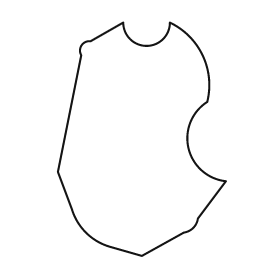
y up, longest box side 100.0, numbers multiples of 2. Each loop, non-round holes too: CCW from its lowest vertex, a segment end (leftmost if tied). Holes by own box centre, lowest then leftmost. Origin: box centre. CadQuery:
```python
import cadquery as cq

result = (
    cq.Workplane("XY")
    .moveTo(0.0, -50.0)
    .lineTo(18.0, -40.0)
    .threePointArc((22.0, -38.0), (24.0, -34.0))
    .lineTo(36.0, -18.0)
    .threePointArc((20.0, -4.0), (28.0, 16.0))
    .threePointArc((26.0, 36.0), (12.0, 50.0))
    .threePointArc((2.0, 40.0), (-8.0, 50.0))
    .lineTo(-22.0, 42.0)
    .threePointArc((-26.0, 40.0), (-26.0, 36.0))
    .lineTo(-36.0, -14.0)
    .lineTo(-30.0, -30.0)
    .threePointArc((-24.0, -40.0), (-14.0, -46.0))
    .close()
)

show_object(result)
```